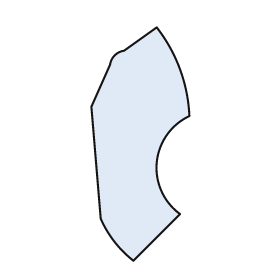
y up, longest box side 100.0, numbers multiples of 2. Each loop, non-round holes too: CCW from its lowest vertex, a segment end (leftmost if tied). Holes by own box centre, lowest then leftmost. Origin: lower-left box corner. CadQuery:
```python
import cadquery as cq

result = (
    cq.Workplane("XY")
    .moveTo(18.0, 0.0)
    .lineTo(38.0, 20.0)
    .threePointArc((28.0, 42.0), (42.0, 62.0))
    .threePointArc((38.0, 82.0), (28.0, 100.0))
    .lineTo(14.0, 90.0)
    .threePointArc((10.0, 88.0), (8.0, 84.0))
    .lineTo(0.0, 66.0)
    .lineTo(4.0, 18.0)
    .threePointArc((10.0, 8.0), (18.0, 0.0))
    .close()
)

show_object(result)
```